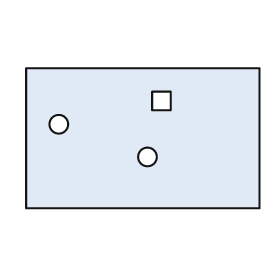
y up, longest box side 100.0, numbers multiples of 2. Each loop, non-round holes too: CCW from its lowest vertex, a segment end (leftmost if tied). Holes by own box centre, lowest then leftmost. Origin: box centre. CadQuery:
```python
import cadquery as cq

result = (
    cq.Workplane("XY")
    .moveTo(-50.0, -30.0)
    .lineTo(50.0, -30.0)
    .lineTo(50.0, 30.0)
    .lineTo(-50.0, 30.0)
    .close()
    .moveTo(2.0, -8.0)
    .circle(4.0)
    .moveTo(-36.0, 6.0)
    .circle(4.0)
    .moveTo(4.0, 12.0)
    .lineTo(12.0, 12.0)
    .lineTo(12.0, 20.0)
    .lineTo(4.0, 20.0)
    .close()
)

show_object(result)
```